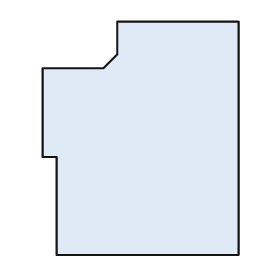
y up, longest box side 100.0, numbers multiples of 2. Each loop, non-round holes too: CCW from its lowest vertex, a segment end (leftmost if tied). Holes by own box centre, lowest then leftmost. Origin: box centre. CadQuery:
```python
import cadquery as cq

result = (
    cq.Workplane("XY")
    .moveTo(-36.0, -50.0)
    .lineTo(42.0, -50.0)
    .lineTo(42.0, 50.0)
    .lineTo(-10.0, 50.0)
    .lineTo(-10.0, 36.0)
    .lineTo(-16.0, 30.0)
    .lineTo(-42.0, 30.0)
    .lineTo(-42.0, -8.0)
    .lineTo(-36.0, -8.0)
    .close()
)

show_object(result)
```